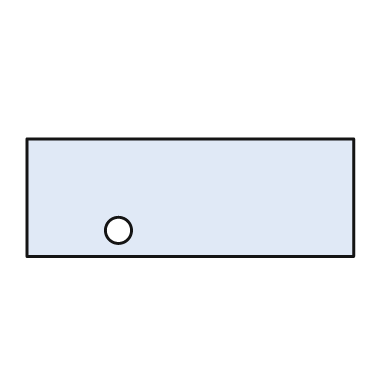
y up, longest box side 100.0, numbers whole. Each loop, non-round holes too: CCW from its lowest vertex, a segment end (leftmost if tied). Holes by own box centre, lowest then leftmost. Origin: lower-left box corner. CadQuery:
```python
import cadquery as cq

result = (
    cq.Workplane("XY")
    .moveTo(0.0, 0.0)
    .lineTo(100.0, 0.0)
    .lineTo(100.0, 36.0)
    .lineTo(0.0, 36.0)
    .close()
    .moveTo(28.0, 8.0)
    .circle(4.0)
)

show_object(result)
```